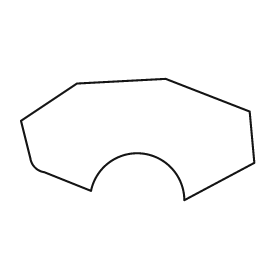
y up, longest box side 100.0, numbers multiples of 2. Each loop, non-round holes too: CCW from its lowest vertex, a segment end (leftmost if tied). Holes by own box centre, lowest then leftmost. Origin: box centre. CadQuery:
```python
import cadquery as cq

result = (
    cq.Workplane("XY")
    .moveTo(20.0, -26.0)
    .lineTo(50.0, -10.0)
    .lineTo(48.0, 12.0)
    .lineTo(12.0, 26.0)
    .lineTo(-26.0, 24.0)
    .lineTo(-50.0, 8.0)
    .lineTo(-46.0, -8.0)
    .threePointArc((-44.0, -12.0), (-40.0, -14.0))
    .lineTo(-20.0, -22.0)
    .threePointArc((2.0, -6.0), (20.0, -26.0))
    .close()
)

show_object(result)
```